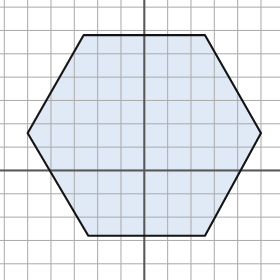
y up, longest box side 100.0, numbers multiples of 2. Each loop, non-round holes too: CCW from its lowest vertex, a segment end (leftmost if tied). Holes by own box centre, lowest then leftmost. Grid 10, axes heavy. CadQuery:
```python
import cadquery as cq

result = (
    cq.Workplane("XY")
    .moveTo(-24.0, -28.0)
    .lineTo(26.0, -28.0)
    .lineTo(50.0, 16.0)
    .lineTo(26.0, 58.0)
    .lineTo(-26.0, 58.0)
    .lineTo(-50.0, 16.0)
    .close()
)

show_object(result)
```